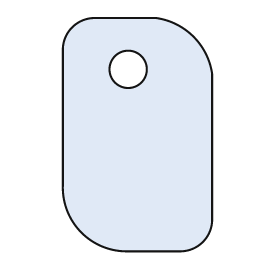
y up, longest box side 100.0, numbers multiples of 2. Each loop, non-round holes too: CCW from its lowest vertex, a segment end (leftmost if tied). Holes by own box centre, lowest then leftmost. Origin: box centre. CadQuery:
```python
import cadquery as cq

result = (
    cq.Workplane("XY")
    .moveTo(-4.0, -50.0)
    .lineTo(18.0, -50.0)
    .threePointArc((28.0, -46.0), (32.0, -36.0))
    .lineTo(32.0, 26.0)
    .threePointArc((24.0, 42.0), (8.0, 50.0))
    .lineTo(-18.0, 50.0)
    .threePointArc((-28.0, 46.0), (-32.0, 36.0))
    .lineTo(-32.0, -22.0)
    .threePointArc((-24.0, -42.0), (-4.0, -50.0))
    .close()
    .moveTo(-4.0, 28.0)
    .circle(8.0)
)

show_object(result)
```